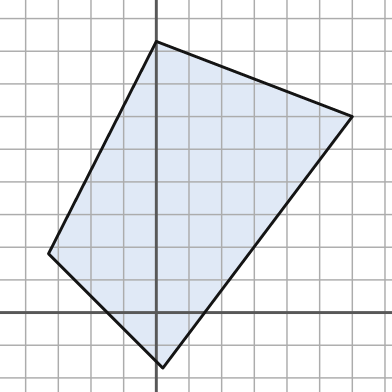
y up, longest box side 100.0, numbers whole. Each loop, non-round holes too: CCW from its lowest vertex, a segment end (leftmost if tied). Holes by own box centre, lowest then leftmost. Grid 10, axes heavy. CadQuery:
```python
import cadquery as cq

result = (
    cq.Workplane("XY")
    .moveTo(2.0, -17.0)
    .lineTo(60.0, 60.0)
    .lineTo(0.0, 83.0)
    .lineTo(-33.0, 18.0)
    .close()
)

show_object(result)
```